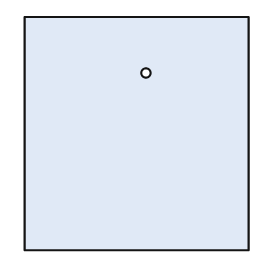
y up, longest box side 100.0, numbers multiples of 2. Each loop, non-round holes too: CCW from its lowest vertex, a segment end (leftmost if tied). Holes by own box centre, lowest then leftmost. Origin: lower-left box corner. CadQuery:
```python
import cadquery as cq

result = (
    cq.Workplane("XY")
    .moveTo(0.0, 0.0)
    .lineTo(96.0, 0.0)
    .lineTo(96.0, 100.0)
    .lineTo(0.0, 100.0)
    .close()
    .moveTo(52.0, 76.0)
    .circle(2.0)
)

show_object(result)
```